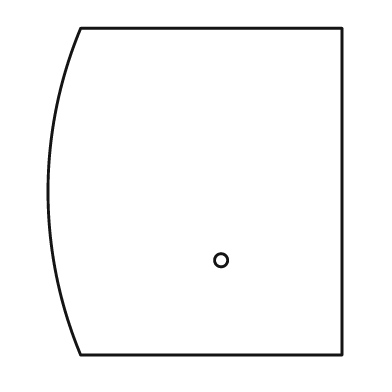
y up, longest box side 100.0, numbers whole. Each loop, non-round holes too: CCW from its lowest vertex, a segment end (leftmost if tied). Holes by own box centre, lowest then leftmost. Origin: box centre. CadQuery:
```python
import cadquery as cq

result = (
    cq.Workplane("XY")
    .moveTo(-35.0, -50.0)
    .lineTo(45.0, -50.0)
    .lineTo(45.0, 50.0)
    .lineTo(-35.0, 50.0)
    .threePointArc((-45.0, 0.0), (-35.0, -50.0))
    .close()
    .moveTo(8.0, -21.0)
    .circle(2.0)
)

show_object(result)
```